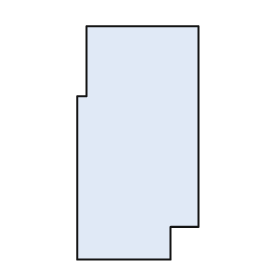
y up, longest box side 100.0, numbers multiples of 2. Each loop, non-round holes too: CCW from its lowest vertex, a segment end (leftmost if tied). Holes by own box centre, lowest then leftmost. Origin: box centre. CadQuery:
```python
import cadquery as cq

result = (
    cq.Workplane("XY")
    .moveTo(-26.0, -50.0)
    .lineTo(14.0, -50.0)
    .lineTo(14.0, -36.0)
    .lineTo(26.0, -36.0)
    .lineTo(26.0, 50.0)
    .lineTo(-22.0, 50.0)
    .lineTo(-22.0, 20.0)
    .lineTo(-26.0, 20.0)
    .close()
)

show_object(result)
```